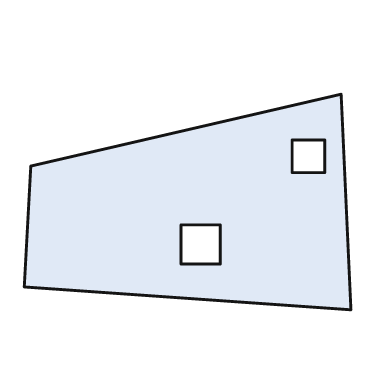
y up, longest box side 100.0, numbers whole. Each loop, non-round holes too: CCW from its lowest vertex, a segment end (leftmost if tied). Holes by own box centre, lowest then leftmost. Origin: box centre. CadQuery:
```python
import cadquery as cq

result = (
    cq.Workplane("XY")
    .moveTo(50.0, -33.0)
    .lineTo(47.0, 33.0)
    .lineTo(-48.0, 11.0)
    .lineTo(-50.0, -26.0)
    .close()
    .moveTo(-2.0, -19.0)
    .lineTo(10.0, -19.0)
    .lineTo(10.0, -7.0)
    .lineTo(-2.0, -7.0)
    .close()
    .moveTo(32.0, 9.0)
    .lineTo(42.0, 9.0)
    .lineTo(42.0, 19.0)
    .lineTo(32.0, 19.0)
    .close()
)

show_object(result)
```